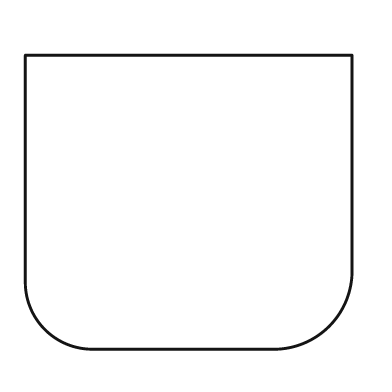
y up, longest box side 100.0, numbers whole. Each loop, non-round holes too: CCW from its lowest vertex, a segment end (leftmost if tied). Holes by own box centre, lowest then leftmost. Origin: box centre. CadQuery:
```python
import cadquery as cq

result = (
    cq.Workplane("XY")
    .moveTo(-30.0, -45.0)
    .lineTo(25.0, -45.0)
    .threePointArc((43.0, -38.0), (50.0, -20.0))
    .lineTo(50.0, 45.0)
    .lineTo(-50.0, 45.0)
    .lineTo(-50.0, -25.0)
    .threePointArc((-44.0, -39.0), (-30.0, -45.0))
    .close()
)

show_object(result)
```